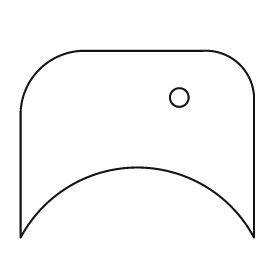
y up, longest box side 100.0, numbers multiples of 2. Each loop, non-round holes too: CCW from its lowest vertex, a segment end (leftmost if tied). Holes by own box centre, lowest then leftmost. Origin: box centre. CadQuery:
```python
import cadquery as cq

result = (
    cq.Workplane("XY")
    .moveTo(-50.0, -40.0)
    .threePointArc((0.0, -10.0), (50.0, -40.0))
    .lineTo(50.0, 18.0)
    .threePointArc((44.0, 34.0), (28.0, 40.0))
    .lineTo(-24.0, 40.0)
    .threePointArc((-42.0, 32.0), (-50.0, 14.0))
    .close()
    .moveTo(18.0, 20.0)
    .circle(4.0)
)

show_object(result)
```